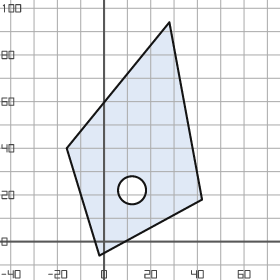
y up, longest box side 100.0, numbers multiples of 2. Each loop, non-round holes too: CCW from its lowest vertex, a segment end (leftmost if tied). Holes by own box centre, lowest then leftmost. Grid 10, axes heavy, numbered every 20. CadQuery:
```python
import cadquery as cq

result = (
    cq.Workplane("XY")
    .moveTo(-2.0, -6.0)
    .lineTo(42.0, 18.0)
    .lineTo(28.0, 94.0)
    .lineTo(-16.0, 40.0)
    .close()
    .moveTo(12.0, 22.0)
    .circle(6.0)
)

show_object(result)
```